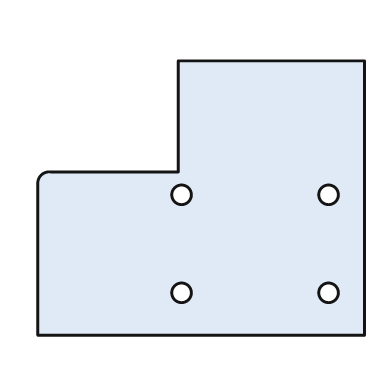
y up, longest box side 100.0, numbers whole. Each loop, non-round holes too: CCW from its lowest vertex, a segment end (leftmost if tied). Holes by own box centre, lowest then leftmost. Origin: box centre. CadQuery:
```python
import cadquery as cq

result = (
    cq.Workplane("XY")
    .moveTo(-50.0, -42.0)
    .lineTo(50.0, -42.0)
    .lineTo(50.0, 42.0)
    .lineTo(-7.0, 42.0)
    .lineTo(-7.0, 8.0)
    .lineTo(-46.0, 8.0)
    .threePointArc((-49.0, 7.0), (-50.0, 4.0))
    .close()
    .moveTo(-6.0, -29.0)
    .circle(3.0)
    .moveTo(39.0, -29.0)
    .circle(3.0)
    .moveTo(-6.0, 1.0)
    .circle(3.0)
    .moveTo(39.0, 1.0)
    .circle(3.0)
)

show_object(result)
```